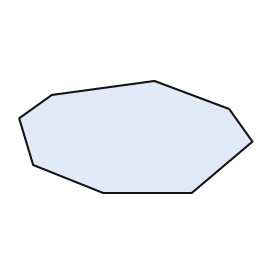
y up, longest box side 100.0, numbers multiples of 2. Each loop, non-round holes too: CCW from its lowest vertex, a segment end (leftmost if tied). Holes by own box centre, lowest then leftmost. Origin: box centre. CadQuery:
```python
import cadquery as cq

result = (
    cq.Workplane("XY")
    .moveTo(-14.0, -24.0)
    .lineTo(24.0, -24.0)
    .lineTo(50.0, -2.0)
    .lineTo(40.0, 12.0)
    .lineTo(8.0, 24.0)
    .lineTo(-36.0, 18.0)
    .lineTo(-50.0, 8.0)
    .lineTo(-44.0, -12.0)
    .close()
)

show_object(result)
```